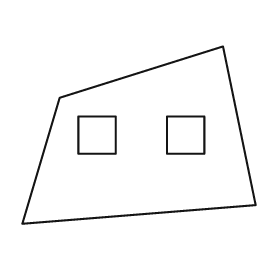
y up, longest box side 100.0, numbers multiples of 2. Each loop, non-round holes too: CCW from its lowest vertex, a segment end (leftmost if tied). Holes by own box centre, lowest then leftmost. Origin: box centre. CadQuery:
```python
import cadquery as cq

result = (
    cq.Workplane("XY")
    .moveTo(-50.0, -38.0)
    .lineTo(50.0, -30.0)
    .lineTo(36.0, 38.0)
    .lineTo(-34.0, 16.0)
    .close()
    .moveTo(-26.0, -8.0)
    .lineTo(-10.0, -8.0)
    .lineTo(-10.0, 8.0)
    .lineTo(-26.0, 8.0)
    .close()
    .moveTo(12.0, -8.0)
    .lineTo(28.0, -8.0)
    .lineTo(28.0, 8.0)
    .lineTo(12.0, 8.0)
    .close()
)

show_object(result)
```